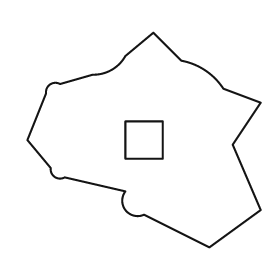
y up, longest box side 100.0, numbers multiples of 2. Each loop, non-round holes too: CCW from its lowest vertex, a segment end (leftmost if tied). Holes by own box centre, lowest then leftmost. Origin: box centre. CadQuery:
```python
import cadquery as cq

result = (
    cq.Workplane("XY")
    .moveTo(28.0, -46.0)
    .lineTo(50.0, -30.0)
    .lineTo(38.0, -2.0)
    .lineTo(50.0, 16.0)
    .lineTo(34.0, 22.0)
    .threePointArc((26.0, 30.0), (16.0, 34.0))
    .lineTo(4.0, 46.0)
    .lineTo(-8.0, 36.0)
    .threePointArc((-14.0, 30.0), (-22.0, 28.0))
    .lineTo(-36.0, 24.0)
    .threePointArc((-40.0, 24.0), (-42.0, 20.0))
    .lineTo(-50.0, 0.0)
    .lineTo(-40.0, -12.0)
    .threePointArc((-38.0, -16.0), (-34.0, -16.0))
    .lineTo(-8.0, -22.0)
    .threePointArc((-8.0, -30.0), (0.0, -32.0))
    .close()
    .moveTo(-8.0, -8.0)
    .lineTo(8.0, -8.0)
    .lineTo(8.0, 8.0)
    .lineTo(-8.0, 8.0)
    .close()
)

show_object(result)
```